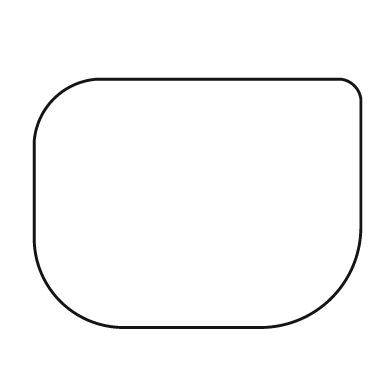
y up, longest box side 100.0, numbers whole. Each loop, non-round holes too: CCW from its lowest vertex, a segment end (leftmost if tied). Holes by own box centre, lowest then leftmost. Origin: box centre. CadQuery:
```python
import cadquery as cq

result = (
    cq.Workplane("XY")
    .moveTo(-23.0, -38.0)
    .lineTo(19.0, -38.0)
    .threePointArc((41.0, -29.0), (50.0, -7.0))
    .lineTo(50.0, 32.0)
    .threePointArc((48.0, 36.0), (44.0, 38.0))
    .lineTo(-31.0, 38.0)
    .threePointArc((-44.0, 32.0), (-50.0, 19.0))
    .lineTo(-50.0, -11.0)
    .threePointArc((-42.0, -30.0), (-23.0, -38.0))
    .close()
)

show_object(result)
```